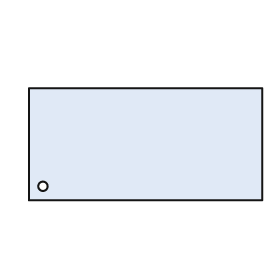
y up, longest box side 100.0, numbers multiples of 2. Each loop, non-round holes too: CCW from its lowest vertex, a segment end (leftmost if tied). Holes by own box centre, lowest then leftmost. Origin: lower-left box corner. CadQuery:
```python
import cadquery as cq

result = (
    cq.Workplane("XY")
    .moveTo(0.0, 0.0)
    .lineTo(100.0, 0.0)
    .lineTo(100.0, 48.0)
    .lineTo(0.0, 48.0)
    .close()
    .moveTo(6.0, 6.0)
    .circle(2.0)
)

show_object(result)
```